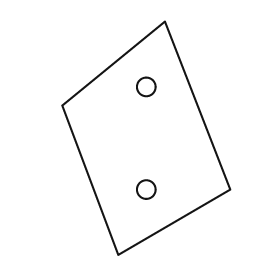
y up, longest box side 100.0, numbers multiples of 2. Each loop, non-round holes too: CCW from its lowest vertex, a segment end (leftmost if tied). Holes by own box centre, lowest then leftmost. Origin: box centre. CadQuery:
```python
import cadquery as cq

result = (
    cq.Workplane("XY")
    .moveTo(-12.0, -50.0)
    .lineTo(36.0, -22.0)
    .lineTo(8.0, 50.0)
    .lineTo(-36.0, 14.0)
    .close()
    .moveTo(0.0, -22.0)
    .circle(4.0)
    .moveTo(0.0, 22.0)
    .circle(4.0)
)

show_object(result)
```